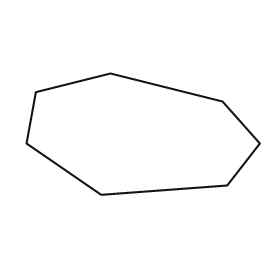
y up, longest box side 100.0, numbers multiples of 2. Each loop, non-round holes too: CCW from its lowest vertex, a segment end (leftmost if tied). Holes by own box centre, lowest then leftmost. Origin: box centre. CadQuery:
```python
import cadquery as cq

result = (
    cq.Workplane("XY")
    .moveTo(-18.0, -26.0)
    .lineTo(36.0, -22.0)
    .lineTo(50.0, -4.0)
    .lineTo(34.0, 14.0)
    .lineTo(-14.0, 26.0)
    .lineTo(-46.0, 18.0)
    .lineTo(-50.0, -4.0)
    .close()
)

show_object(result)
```